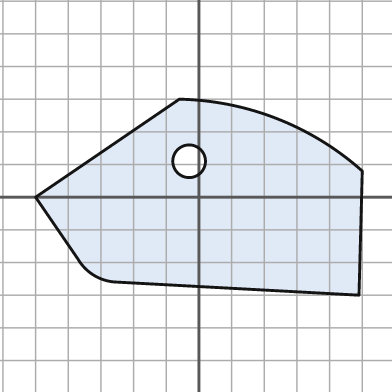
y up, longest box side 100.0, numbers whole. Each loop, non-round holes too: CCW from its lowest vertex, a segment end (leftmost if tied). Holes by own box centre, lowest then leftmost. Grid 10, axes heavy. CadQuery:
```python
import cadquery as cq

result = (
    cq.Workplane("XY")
    .moveTo(49.0, -30.0)
    .lineTo(50.0, 8.0)
    .threePointArc((24.0, 24.0), (-6.0, 30.0))
    .lineTo(-50.0, 0.0)
    .lineTo(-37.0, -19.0)
    .threePointArc((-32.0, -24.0), (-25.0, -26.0))
    .close()
    .moveTo(-3.0, 11.0)
    .circle(5.0)
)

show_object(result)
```